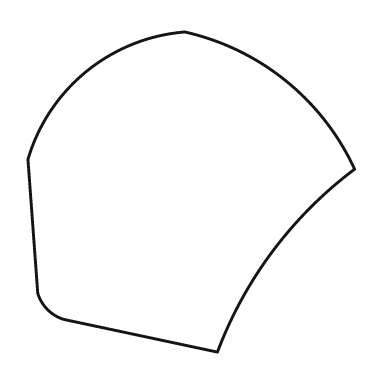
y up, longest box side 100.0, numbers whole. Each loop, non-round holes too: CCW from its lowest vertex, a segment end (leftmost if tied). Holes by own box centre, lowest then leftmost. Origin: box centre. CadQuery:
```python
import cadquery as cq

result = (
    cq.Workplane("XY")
    .moveTo(8.0, -49.0)
    .threePointArc((25.0, -18.0), (50.0, 7.0))
    .threePointArc((29.0, 34.0), (-2.0, 49.0))
    .threePointArc((-32.0, 37.0), (-50.0, 10.0))
    .lineTo(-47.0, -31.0)
    .threePointArc((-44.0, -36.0), (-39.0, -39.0))
    .close()
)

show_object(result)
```